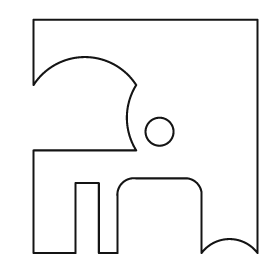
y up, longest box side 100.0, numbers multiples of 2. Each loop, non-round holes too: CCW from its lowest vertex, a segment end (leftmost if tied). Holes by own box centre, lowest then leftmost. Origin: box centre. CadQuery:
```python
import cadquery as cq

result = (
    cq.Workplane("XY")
    .moveTo(-48.0, -50.0)
    .lineTo(-30.0, -50.0)
    .lineTo(-30.0, -20.0)
    .lineTo(-20.0, -20.0)
    .lineTo(-20.0, -50.0)
    .lineTo(-12.0, -50.0)
    .lineTo(-12.0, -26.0)
    .threePointArc((-10.0, -20.0), (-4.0, -18.0))
    .lineTo(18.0, -18.0)
    .threePointArc((22.0, -20.0), (24.0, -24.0))
    .lineTo(24.0, -50.0)
    .threePointArc((36.0, -44.0), (48.0, -50.0))
    .lineTo(48.0, 50.0)
    .lineTo(-48.0, 50.0)
    .lineTo(-48.0, 22.0)
    .threePointArc((-26.0, 34.0), (-4.0, 22.0))
    .threePointArc((-8.0, 8.0), (-4.0, -6.0))
    .lineTo(-48.0, -6.0)
    .close()
    .moveTo(6.0, 2.0)
    .circle(6.0)
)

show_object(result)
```